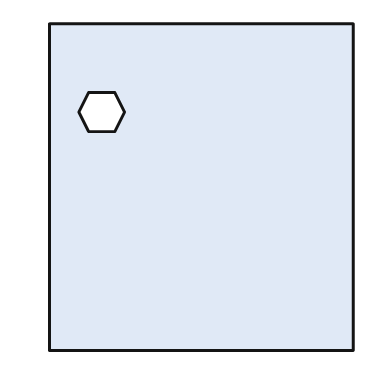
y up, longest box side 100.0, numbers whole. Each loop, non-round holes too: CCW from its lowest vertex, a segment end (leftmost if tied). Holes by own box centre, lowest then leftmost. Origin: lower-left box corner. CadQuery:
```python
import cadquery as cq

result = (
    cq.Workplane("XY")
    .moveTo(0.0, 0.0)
    .lineTo(93.0, 0.0)
    .lineTo(93.0, 100.0)
    .lineTo(0.0, 100.0)
    .close()
    .moveTo(12.0, 67.0)
    .lineTo(20.0, 67.0)
    .lineTo(23.0, 73.0)
    .lineTo(20.0, 79.0)
    .lineTo(12.0, 79.0)
    .lineTo(9.0, 73.0)
    .close()
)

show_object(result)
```